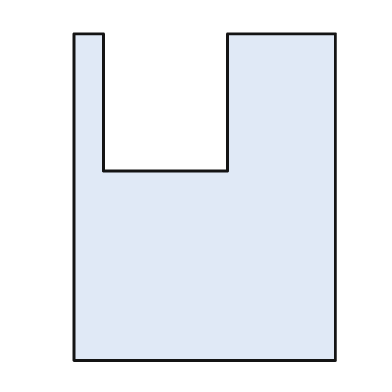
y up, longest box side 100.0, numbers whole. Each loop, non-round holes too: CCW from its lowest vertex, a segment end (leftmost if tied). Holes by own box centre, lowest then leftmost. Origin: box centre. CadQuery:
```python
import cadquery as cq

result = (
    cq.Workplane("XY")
    .moveTo(-40.0, -50.0)
    .lineTo(40.0, -50.0)
    .lineTo(40.0, 50.0)
    .lineTo(7.0, 50.0)
    .lineTo(7.0, 8.0)
    .lineTo(-31.0, 8.0)
    .lineTo(-31.0, 50.0)
    .lineTo(-40.0, 50.0)
    .close()
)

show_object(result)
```